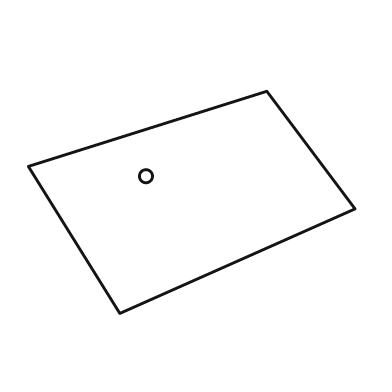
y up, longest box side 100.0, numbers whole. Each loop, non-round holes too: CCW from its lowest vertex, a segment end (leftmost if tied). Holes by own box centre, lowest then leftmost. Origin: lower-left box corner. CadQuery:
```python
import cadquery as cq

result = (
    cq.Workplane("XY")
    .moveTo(28.0, 0.0)
    .lineTo(100.0, 32.0)
    .lineTo(73.0, 68.0)
    .lineTo(0.0, 45.0)
    .close()
    .moveTo(36.0, 42.0)
    .circle(2.0)
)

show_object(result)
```